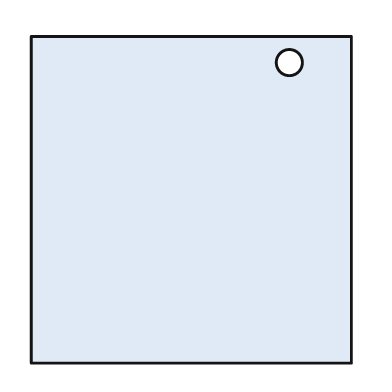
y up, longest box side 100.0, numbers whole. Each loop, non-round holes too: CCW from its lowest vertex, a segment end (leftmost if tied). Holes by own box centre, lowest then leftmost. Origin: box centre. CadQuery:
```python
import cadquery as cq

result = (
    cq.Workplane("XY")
    .moveTo(-49.0, -50.0)
    .lineTo(49.0, -50.0)
    .lineTo(49.0, 50.0)
    .lineTo(-49.0, 50.0)
    .close()
    .moveTo(30.0, 42.0)
    .circle(4.0)
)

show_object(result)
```